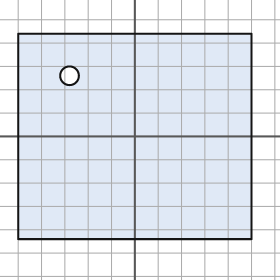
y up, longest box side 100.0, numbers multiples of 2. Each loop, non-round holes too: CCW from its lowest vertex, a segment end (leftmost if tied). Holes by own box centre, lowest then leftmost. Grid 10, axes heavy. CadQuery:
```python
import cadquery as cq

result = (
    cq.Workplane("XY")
    .moveTo(-50.0, -44.0)
    .lineTo(50.0, -44.0)
    .lineTo(50.0, 44.0)
    .lineTo(-50.0, 44.0)
    .close()
    .moveTo(-28.0, 26.0)
    .circle(4.0)
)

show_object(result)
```